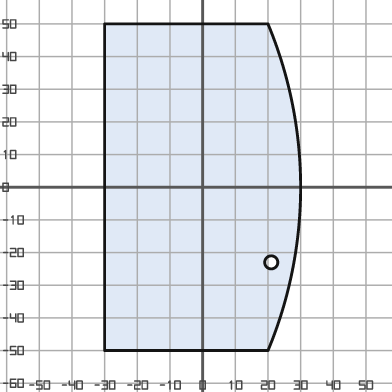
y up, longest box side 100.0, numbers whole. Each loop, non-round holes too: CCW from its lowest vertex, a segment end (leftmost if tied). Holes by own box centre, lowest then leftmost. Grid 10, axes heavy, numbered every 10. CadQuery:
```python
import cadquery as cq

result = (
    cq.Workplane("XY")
    .moveTo(-30.0, -50.0)
    .lineTo(20.0, -50.0)
    .threePointArc((30.0, 0.0), (20.0, 50.0))
    .lineTo(-30.0, 50.0)
    .close()
    .moveTo(21.0, -23.0)
    .circle(2.0)
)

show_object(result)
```